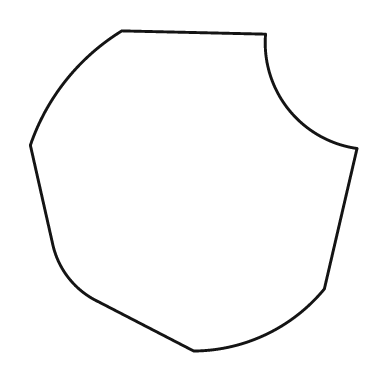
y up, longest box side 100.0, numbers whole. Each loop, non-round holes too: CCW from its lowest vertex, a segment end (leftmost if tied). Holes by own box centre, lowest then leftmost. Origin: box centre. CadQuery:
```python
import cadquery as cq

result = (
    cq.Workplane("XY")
    .moveTo(0.0, -49.0)
    .threePointArc((22.0, -44.0), (40.0, -30.0))
    .lineTo(50.0, 13.0)
    .threePointArc((29.0, 25.0), (22.0, 48.0))
    .lineTo(-22.0, 49.0)
    .threePointArc((-39.0, 34.0), (-50.0, 14.0))
    .lineTo(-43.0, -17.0)
    .threePointArc((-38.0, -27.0), (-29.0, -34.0))
    .close()
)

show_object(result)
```